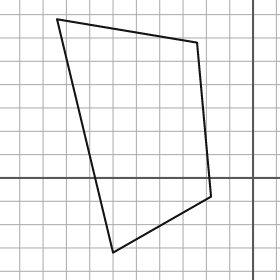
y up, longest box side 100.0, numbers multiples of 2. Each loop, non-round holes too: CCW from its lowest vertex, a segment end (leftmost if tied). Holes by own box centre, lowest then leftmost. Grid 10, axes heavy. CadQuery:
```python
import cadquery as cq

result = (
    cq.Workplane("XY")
    .moveTo(-60.0, -32.0)
    .lineTo(-18.0, -8.0)
    .lineTo(-24.0, 58.0)
    .lineTo(-84.0, 68.0)
    .close()
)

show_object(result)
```